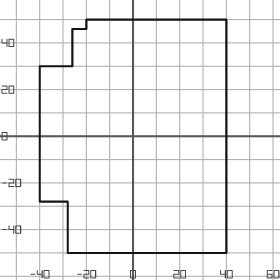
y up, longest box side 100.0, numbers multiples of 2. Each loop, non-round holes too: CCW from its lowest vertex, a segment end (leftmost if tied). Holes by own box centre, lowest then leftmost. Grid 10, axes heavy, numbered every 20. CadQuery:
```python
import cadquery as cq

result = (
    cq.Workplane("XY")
    .moveTo(-28.0, -50.0)
    .lineTo(40.0, -50.0)
    .lineTo(40.0, 50.0)
    .lineTo(-20.0, 50.0)
    .lineTo(-20.0, 46.0)
    .lineTo(-26.0, 46.0)
    .lineTo(-26.0, 30.0)
    .lineTo(-40.0, 30.0)
    .lineTo(-40.0, -28.0)
    .lineTo(-28.0, -28.0)
    .close()
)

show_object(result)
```